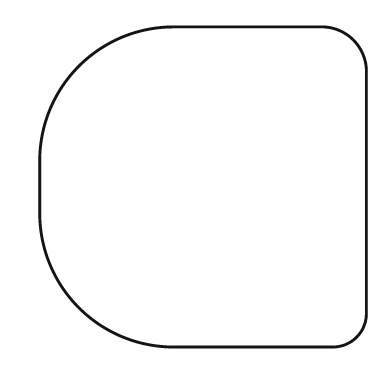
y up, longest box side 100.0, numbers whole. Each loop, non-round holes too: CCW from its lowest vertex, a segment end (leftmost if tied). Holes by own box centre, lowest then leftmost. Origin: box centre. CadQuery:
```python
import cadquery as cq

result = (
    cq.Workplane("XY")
    .moveTo(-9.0, -49.0)
    .lineTo(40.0, -49.0)
    .threePointArc((47.0, -46.0), (50.0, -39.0))
    .lineTo(50.0, 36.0)
    .threePointArc((46.0, 45.0), (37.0, 49.0))
    .lineTo(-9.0, 49.0)
    .threePointArc((-38.0, 37.0), (-50.0, 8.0))
    .lineTo(-50.0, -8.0)
    .threePointArc((-38.0, -37.0), (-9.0, -49.0))
    .close()
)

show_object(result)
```